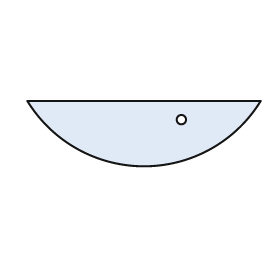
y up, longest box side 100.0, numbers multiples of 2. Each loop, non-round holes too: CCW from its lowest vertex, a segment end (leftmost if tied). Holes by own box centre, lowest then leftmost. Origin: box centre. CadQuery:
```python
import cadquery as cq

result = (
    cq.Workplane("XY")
    .moveTo(-50.0, 14.0)
    .threePointArc((0.0, -14.0), (50.0, 14.0))
    .close()
    .moveTo(16.0, 6.0)
    .circle(2.0)
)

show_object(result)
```